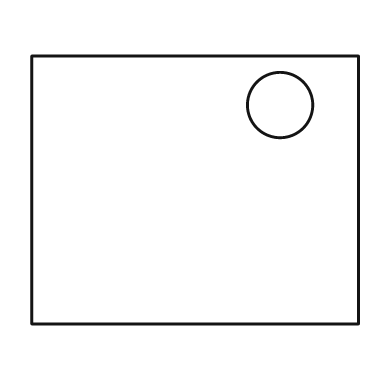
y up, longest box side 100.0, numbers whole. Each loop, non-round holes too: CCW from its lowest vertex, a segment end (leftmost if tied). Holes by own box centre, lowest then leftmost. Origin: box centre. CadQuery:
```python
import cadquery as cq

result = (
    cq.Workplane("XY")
    .moveTo(-50.0, -41.0)
    .lineTo(50.0, -41.0)
    .lineTo(50.0, 41.0)
    .lineTo(-50.0, 41.0)
    .close()
    .moveTo(26.0, 26.0)
    .circle(10.0)
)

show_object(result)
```